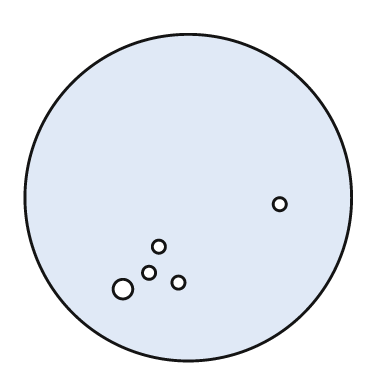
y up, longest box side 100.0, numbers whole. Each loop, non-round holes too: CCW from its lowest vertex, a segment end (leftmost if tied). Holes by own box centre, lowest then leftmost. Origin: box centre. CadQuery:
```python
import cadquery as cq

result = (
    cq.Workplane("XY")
    .moveTo(0.0, 0.0)
    .circle(50.0)
    .moveTo(-20.0, -28.0)
    .circle(3.0)
    .moveTo(-3.0, -26.0)
    .circle(2.0)
    .moveTo(-12.0, -23.0)
    .circle(2.0)
    .moveTo(-9.0, -15.0)
    .circle(2.0)
    .moveTo(28.0, -2.0)
    .circle(2.0)
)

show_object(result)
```